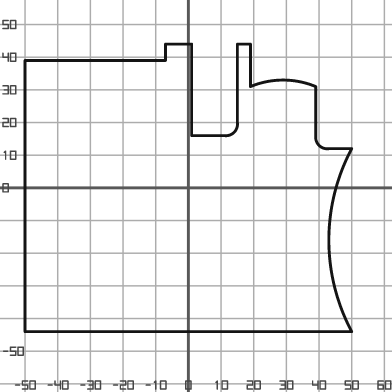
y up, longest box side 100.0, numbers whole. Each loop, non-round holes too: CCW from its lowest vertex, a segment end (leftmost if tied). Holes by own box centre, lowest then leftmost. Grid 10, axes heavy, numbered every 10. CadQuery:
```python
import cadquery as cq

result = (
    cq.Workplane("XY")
    .moveTo(-50.0, -44.0)
    .lineTo(50.0, -44.0)
    .threePointArc((43.0, -16.0), (50.0, 12.0))
    .lineTo(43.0, 12.0)
    .threePointArc((40.0, 13.0), (39.0, 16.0))
    .lineTo(39.0, 31.0)
    .threePointArc((29.0, 33.0), (19.0, 31.0))
    .lineTo(19.0, 44.0)
    .lineTo(15.0, 44.0)
    .lineTo(15.0, 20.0)
    .threePointArc((14.0, 17.0), (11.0, 16.0))
    .lineTo(1.0, 16.0)
    .lineTo(1.0, 44.0)
    .lineTo(-7.0, 44.0)
    .lineTo(-7.0, 39.0)
    .lineTo(-50.0, 39.0)
    .close()
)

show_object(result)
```